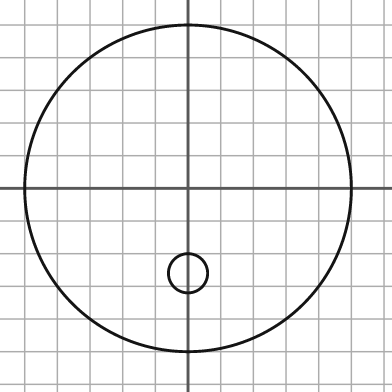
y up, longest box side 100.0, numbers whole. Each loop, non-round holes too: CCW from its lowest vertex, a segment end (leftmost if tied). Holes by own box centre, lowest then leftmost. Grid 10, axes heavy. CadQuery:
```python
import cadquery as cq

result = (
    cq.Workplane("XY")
    .moveTo(0.0, 0.0)
    .circle(50.0)
    .moveTo(0.0, -26.0)
    .circle(6.0)
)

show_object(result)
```